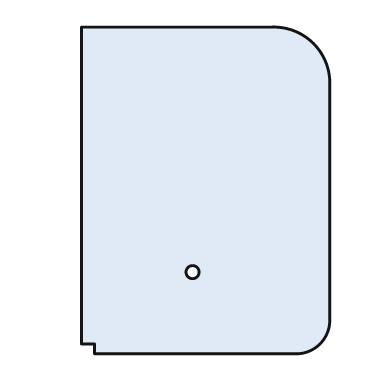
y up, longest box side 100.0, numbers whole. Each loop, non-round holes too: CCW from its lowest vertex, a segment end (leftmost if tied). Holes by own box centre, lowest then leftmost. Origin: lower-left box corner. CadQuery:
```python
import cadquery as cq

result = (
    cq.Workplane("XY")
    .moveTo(4.0, 0.0)
    .lineTo(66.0, 0.0)
    .threePointArc((73.0, 3.0), (76.0, 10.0))
    .lineTo(76.0, 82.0)
    .threePointArc((71.0, 95.0), (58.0, 100.0))
    .lineTo(0.0, 100.0)
    .lineTo(0.0, 3.0)
    .lineTo(4.0, 3.0)
    .close()
    .moveTo(34.0, 25.0)
    .circle(2.0)
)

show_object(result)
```